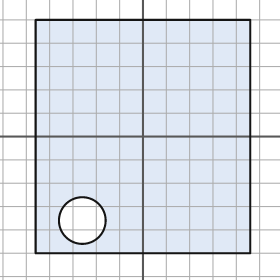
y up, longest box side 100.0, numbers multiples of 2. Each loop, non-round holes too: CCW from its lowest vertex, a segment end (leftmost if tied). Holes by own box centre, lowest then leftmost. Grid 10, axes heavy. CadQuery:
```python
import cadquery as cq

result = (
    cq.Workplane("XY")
    .moveTo(-46.0, -50.0)
    .lineTo(46.0, -50.0)
    .lineTo(46.0, 50.0)
    .lineTo(-46.0, 50.0)
    .close()
    .moveTo(-26.0, -36.0)
    .circle(10.0)
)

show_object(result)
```